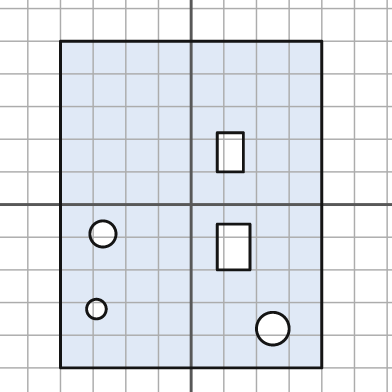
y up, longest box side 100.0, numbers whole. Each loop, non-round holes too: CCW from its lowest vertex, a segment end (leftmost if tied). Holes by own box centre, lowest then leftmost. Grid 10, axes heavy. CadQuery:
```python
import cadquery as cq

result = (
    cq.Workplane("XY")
    .moveTo(-40.0, -50.0)
    .lineTo(40.0, -50.0)
    .lineTo(40.0, 50.0)
    .lineTo(-40.0, 50.0)
    .close()
    .moveTo(25.0, -38.0)
    .circle(5.0)
    .moveTo(-29.0, -32.0)
    .circle(3.0)
    .moveTo(8.0, -20.0)
    .lineTo(18.0, -20.0)
    .lineTo(18.0, -6.0)
    .lineTo(8.0, -6.0)
    .close()
    .moveTo(-27.0, -9.0)
    .circle(4.0)
    .moveTo(8.0, 10.0)
    .lineTo(16.0, 10.0)
    .lineTo(16.0, 22.0)
    .lineTo(8.0, 22.0)
    .close()
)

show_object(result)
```